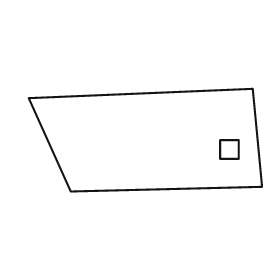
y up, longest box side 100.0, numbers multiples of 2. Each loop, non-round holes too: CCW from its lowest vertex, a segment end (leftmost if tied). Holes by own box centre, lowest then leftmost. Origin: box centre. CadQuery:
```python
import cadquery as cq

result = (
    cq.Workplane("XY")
    .moveTo(-32.0, -22.0)
    .lineTo(50.0, -20.0)
    .lineTo(46.0, 22.0)
    .lineTo(-50.0, 18.0)
    .close()
    .moveTo(32.0, -8.0)
    .lineTo(40.0, -8.0)
    .lineTo(40.0, 0.0)
    .lineTo(32.0, 0.0)
    .close()
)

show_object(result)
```